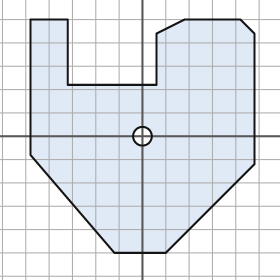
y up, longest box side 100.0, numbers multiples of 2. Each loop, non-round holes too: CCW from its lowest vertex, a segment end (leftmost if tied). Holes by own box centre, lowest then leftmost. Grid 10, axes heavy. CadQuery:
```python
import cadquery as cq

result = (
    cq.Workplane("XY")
    .moveTo(-12.0, -50.0)
    .lineTo(10.0, -50.0)
    .lineTo(48.0, -12.0)
    .lineTo(48.0, 44.0)
    .lineTo(42.0, 50.0)
    .lineTo(18.0, 50.0)
    .lineTo(6.0, 44.0)
    .lineTo(6.0, 22.0)
    .lineTo(-32.0, 22.0)
    .lineTo(-32.0, 50.0)
    .lineTo(-48.0, 50.0)
    .lineTo(-48.0, -8.0)
    .close()
    .moveTo(0.0, 0.0)
    .circle(4.0)
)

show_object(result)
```